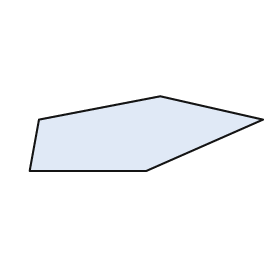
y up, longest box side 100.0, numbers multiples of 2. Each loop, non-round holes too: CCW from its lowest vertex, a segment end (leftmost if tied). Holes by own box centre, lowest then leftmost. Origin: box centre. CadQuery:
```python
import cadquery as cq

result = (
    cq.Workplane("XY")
    .moveTo(-50.0, -16.0)
    .lineTo(0.0, -16.0)
    .lineTo(50.0, 6.0)
    .lineTo(6.0, 16.0)
    .lineTo(-46.0, 6.0)
    .close()
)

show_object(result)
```